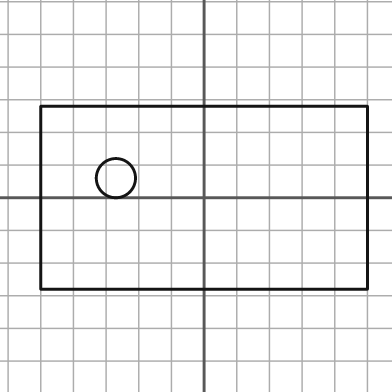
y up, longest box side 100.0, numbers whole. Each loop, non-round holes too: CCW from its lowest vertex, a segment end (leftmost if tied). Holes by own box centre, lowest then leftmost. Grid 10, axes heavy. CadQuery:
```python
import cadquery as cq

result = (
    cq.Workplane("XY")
    .moveTo(-50.0, -28.0)
    .lineTo(50.0, -28.0)
    .lineTo(50.0, 28.0)
    .lineTo(-50.0, 28.0)
    .close()
    .moveTo(-27.0, 6.0)
    .circle(6.0)
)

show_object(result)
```